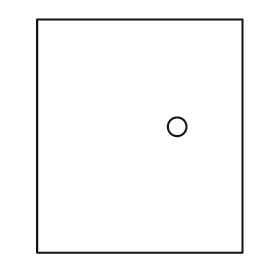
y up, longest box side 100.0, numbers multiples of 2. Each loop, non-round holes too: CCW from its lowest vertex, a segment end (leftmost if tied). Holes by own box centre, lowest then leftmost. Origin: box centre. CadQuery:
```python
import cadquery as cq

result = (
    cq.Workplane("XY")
    .moveTo(-44.0, -50.0)
    .lineTo(44.0, -50.0)
    .lineTo(44.0, 50.0)
    .lineTo(-44.0, 50.0)
    .close()
    .moveTo(16.0, 4.0)
    .circle(4.0)
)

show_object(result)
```